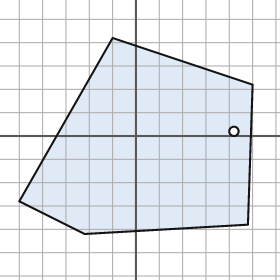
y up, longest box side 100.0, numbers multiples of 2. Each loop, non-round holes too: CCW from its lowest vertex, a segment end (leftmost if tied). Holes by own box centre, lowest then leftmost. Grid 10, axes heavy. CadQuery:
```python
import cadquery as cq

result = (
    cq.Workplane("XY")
    .moveTo(-22.0, -42.0)
    .lineTo(48.0, -38.0)
    .lineTo(50.0, 22.0)
    .lineTo(-10.0, 42.0)
    .lineTo(-50.0, -28.0)
    .close()
    .moveTo(42.0, 2.0)
    .circle(2.0)
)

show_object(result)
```